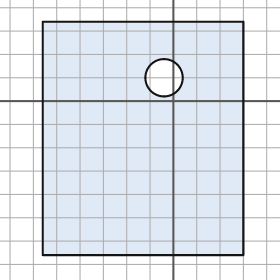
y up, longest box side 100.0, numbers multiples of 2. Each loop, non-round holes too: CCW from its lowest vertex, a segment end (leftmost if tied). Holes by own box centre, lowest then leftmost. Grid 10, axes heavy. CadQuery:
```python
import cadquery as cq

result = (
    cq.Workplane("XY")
    .moveTo(-56.0, -66.0)
    .lineTo(30.0, -66.0)
    .lineTo(30.0, 34.0)
    .lineTo(-56.0, 34.0)
    .close()
    .moveTo(-4.0, 10.0)
    .circle(8.0)
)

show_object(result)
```